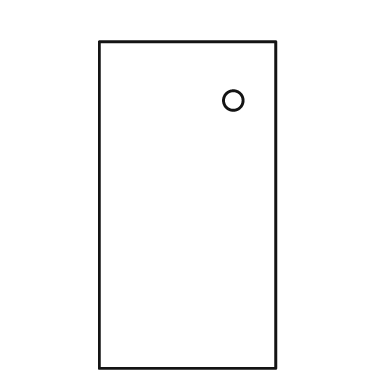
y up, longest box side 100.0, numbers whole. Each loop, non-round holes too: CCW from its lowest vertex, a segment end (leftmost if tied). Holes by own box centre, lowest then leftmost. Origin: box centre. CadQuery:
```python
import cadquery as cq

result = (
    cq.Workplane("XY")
    .moveTo(-27.0, -50.0)
    .lineTo(27.0, -50.0)
    .lineTo(27.0, 50.0)
    .lineTo(-27.0, 50.0)
    .close()
    .moveTo(14.0, 32.0)
    .circle(3.0)
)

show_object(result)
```